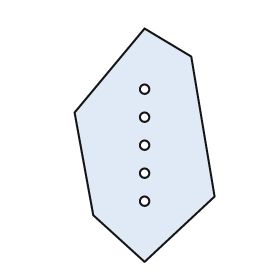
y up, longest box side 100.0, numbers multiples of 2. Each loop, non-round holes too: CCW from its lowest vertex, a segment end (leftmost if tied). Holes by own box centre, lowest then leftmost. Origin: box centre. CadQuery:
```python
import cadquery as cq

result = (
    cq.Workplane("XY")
    .moveTo(0.0, -50.0)
    .lineTo(30.0, -22.0)
    .lineTo(20.0, 38.0)
    .lineTo(0.0, 50.0)
    .lineTo(-30.0, 14.0)
    .lineTo(-22.0, -30.0)
    .close()
    .moveTo(0.0, -24.0)
    .circle(2.0)
    .moveTo(0.0, -12.0)
    .circle(2.0)
    .moveTo(0.0, 0.0)
    .circle(2.0)
    .moveTo(0.0, 12.0)
    .circle(2.0)
    .moveTo(0.0, 24.0)
    .circle(2.0)
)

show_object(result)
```